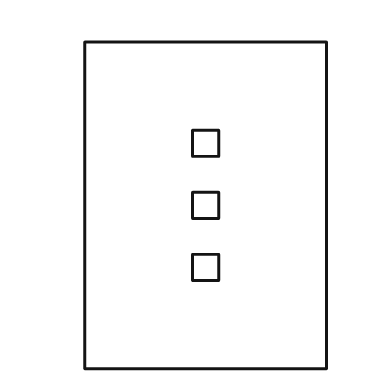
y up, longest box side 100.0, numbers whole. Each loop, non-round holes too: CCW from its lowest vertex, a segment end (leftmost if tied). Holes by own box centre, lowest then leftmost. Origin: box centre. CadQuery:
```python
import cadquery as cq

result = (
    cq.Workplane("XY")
    .moveTo(-37.0, -50.0)
    .lineTo(37.0, -50.0)
    .lineTo(37.0, 50.0)
    .lineTo(-37.0, 50.0)
    .close()
    .moveTo(-4.0, -23.0)
    .lineTo(4.0, -23.0)
    .lineTo(4.0, -15.0)
    .lineTo(-4.0, -15.0)
    .close()
    .moveTo(-4.0, -4.0)
    .lineTo(4.0, -4.0)
    .lineTo(4.0, 4.0)
    .lineTo(-4.0, 4.0)
    .close()
    .moveTo(-4.0, 15.0)
    .lineTo(4.0, 15.0)
    .lineTo(4.0, 23.0)
    .lineTo(-4.0, 23.0)
    .close()
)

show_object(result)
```